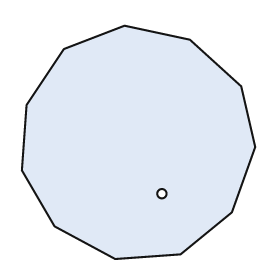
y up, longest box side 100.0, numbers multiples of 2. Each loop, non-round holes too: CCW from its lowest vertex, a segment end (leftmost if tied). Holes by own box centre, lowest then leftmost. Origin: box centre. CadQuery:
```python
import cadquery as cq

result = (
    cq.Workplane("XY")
    .moveTo(-10.0, -50.0)
    .lineTo(18.0, -48.0)
    .lineTo(40.0, -30.0)
    .lineTo(50.0, -2.0)
    .lineTo(44.0, 24.0)
    .lineTo(22.0, 44.0)
    .lineTo(-6.0, 50.0)
    .lineTo(-32.0, 40.0)
    .lineTo(-48.0, 16.0)
    .lineTo(-50.0, -12.0)
    .lineTo(-36.0, -36.0)
    .close()
    .moveTo(10.0, -22.0)
    .circle(2.0)
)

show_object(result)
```